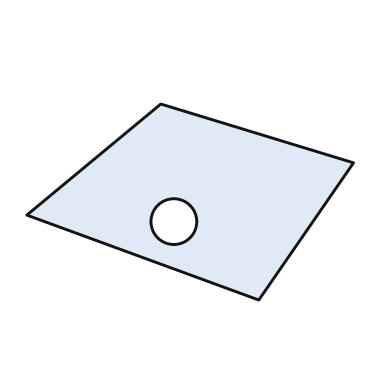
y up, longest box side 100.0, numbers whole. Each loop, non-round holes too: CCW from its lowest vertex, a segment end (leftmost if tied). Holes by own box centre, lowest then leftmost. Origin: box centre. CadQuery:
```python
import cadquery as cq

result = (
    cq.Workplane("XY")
    .moveTo(21.0, -30.0)
    .lineTo(50.0, 12.0)
    .lineTo(-9.0, 30.0)
    .lineTo(-50.0, -4.0)
    .close()
    .moveTo(-5.0, -6.0)
    .circle(7.0)
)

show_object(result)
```